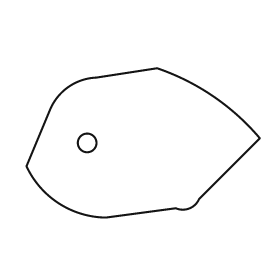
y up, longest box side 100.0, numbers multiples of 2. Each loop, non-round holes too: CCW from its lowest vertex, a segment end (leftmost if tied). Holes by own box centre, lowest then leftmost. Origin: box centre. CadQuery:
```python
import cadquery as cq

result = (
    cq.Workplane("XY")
    .moveTo(-16.0, -32.0)
    .lineTo(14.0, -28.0)
    .threePointArc((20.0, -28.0), (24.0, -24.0))
    .lineTo(50.0, 2.0)
    .threePointArc((30.0, 20.0), (6.0, 32.0))
    .lineTo(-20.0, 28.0)
    .threePointArc((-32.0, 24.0), (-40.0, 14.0))
    .lineTo(-50.0, -10.0)
    .threePointArc((-36.0, -26.0), (-16.0, -32.0))
    .close()
    .moveTo(-24.0, 0.0)
    .circle(4.0)
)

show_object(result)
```